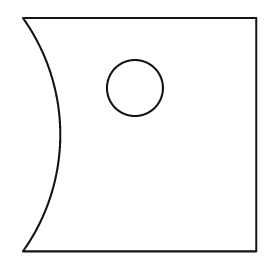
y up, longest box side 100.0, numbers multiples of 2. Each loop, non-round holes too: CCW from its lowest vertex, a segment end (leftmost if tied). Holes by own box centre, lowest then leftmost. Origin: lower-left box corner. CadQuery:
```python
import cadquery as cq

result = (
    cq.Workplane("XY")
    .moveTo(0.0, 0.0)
    .lineTo(100.0, 0.0)
    .lineTo(100.0, 100.0)
    .lineTo(0.0, 100.0)
    .threePointArc((16.0, 50.0), (0.0, 0.0))
    .close()
    .moveTo(48.0, 70.0)
    .circle(12.0)
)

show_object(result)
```